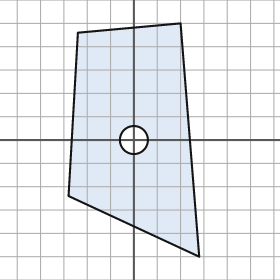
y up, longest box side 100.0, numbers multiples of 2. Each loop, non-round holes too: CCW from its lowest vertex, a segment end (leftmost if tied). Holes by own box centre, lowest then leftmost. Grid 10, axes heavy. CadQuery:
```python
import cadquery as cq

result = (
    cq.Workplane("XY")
    .moveTo(28.0, -50.0)
    .lineTo(20.0, 50.0)
    .lineTo(-24.0, 46.0)
    .lineTo(-28.0, -24.0)
    .close()
    .moveTo(0.0, 0.0)
    .circle(6.0)
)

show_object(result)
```